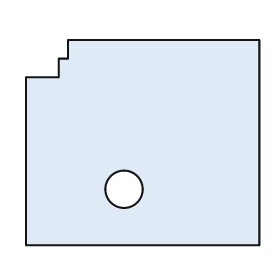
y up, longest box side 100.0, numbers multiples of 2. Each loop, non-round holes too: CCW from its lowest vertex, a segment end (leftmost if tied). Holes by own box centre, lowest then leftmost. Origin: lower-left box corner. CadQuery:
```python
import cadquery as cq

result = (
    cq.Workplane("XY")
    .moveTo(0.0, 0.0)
    .lineTo(100.0, 0.0)
    .lineTo(100.0, 88.0)
    .lineTo(18.0, 88.0)
    .lineTo(18.0, 80.0)
    .lineTo(14.0, 80.0)
    .lineTo(14.0, 72.0)
    .lineTo(0.0, 72.0)
    .close()
    .moveTo(42.0, 24.0)
    .circle(8.0)
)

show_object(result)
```